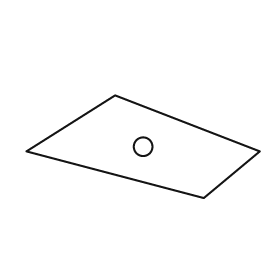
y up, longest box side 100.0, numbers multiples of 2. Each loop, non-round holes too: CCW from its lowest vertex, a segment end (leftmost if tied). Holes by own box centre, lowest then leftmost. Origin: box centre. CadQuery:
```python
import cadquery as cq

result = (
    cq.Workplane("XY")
    .moveTo(26.0, -22.0)
    .lineTo(50.0, -2.0)
    .lineTo(-12.0, 22.0)
    .lineTo(-50.0, -2.0)
    .close()
    .moveTo(0.0, 0.0)
    .circle(4.0)
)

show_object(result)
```